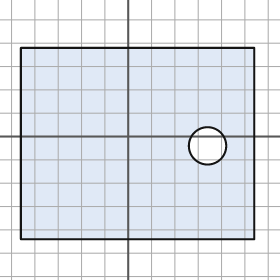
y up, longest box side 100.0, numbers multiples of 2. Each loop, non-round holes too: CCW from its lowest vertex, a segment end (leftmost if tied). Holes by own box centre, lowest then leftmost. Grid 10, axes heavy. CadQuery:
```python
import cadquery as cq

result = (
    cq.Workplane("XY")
    .moveTo(-46.0, -44.0)
    .lineTo(54.0, -44.0)
    .lineTo(54.0, 38.0)
    .lineTo(-46.0, 38.0)
    .close()
    .moveTo(34.0, -4.0)
    .circle(8.0)
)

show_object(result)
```